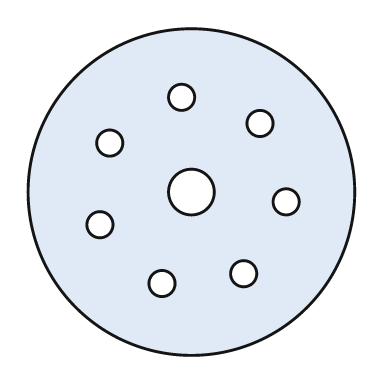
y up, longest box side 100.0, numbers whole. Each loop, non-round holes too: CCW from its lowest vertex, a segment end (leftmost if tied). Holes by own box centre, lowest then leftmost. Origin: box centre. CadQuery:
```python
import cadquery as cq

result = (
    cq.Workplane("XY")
    .moveTo(0.0, 0.0)
    .circle(50.0)
    .moveTo(-9.0, -28.0)
    .circle(4.0)
    .moveTo(16.0, -25.0)
    .circle(4.0)
    .moveTo(-28.0, -10.0)
    .circle(4.0)
    .moveTo(29.0, -3.0)
    .circle(4.0)
    .moveTo(0.0, 0.0)
    .circle(7.0)
    .moveTo(-25.0, 15.0)
    .circle(4.0)
    .moveTo(21.0, 21.0)
    .circle(4.0)
    .moveTo(-3.0, 29.0)
    .circle(4.0)
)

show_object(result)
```